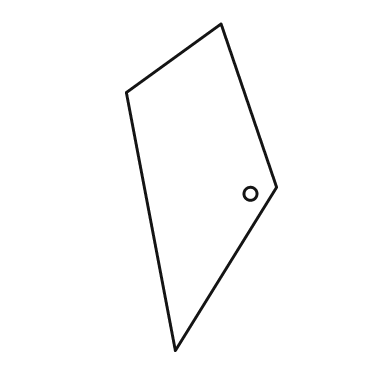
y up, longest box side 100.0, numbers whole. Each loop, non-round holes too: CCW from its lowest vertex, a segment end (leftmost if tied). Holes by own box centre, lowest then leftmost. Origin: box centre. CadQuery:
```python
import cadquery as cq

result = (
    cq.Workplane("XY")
    .moveTo(-8.0, -50.0)
    .lineTo(23.0, 0.0)
    .lineTo(6.0, 50.0)
    .lineTo(-23.0, 29.0)
    .close()
    .moveTo(15.0, -2.0)
    .circle(2.0)
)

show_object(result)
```